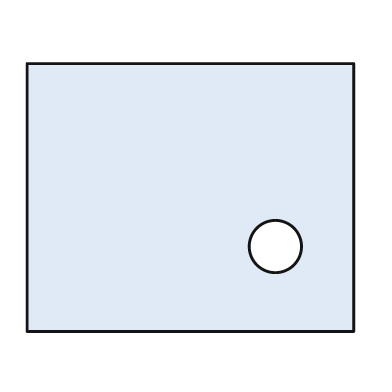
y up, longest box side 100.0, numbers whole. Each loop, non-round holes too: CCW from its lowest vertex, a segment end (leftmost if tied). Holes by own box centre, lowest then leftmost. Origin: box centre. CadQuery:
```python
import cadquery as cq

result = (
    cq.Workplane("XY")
    .moveTo(-50.0, -41.0)
    .lineTo(50.0, -41.0)
    .lineTo(50.0, 41.0)
    .lineTo(-50.0, 41.0)
    .close()
    .moveTo(26.0, -15.0)
    .circle(8.0)
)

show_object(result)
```